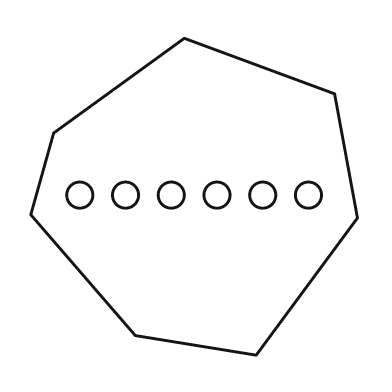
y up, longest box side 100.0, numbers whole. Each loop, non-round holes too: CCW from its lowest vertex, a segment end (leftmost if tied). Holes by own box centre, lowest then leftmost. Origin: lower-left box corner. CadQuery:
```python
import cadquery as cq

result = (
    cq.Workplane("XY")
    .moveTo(69.0, 0.0)
    .lineTo(100.0, 42.0)
    .lineTo(93.0, 80.0)
    .lineTo(47.0, 97.0)
    .lineTo(7.0, 68.0)
    .lineTo(0.0, 43.0)
    .lineTo(32.0, 6.0)
    .close()
    .moveTo(15.0, 49.0)
    .circle(4.0)
    .moveTo(29.0, 49.0)
    .circle(4.0)
    .moveTo(43.0, 49.0)
    .circle(4.0)
    .moveTo(57.0, 49.0)
    .circle(4.0)
    .moveTo(71.0, 49.0)
    .circle(4.0)
    .moveTo(85.0, 49.0)
    .circle(4.0)
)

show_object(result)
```